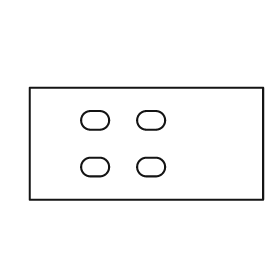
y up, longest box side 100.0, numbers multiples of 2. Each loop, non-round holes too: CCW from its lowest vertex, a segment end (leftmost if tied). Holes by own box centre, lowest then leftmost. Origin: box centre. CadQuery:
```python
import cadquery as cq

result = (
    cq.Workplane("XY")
    .moveTo(-50.0, -24.0)
    .lineTo(50.0, -24.0)
    .lineTo(50.0, 24.0)
    .lineTo(-50.0, 24.0)
    .close()
    .moveTo(-24.0, -14.0)
    .lineTo(-20.0, -14.0)
    .threePointArc((-16.0, -10.0), (-20.0, -6.0))
    .lineTo(-24.0, -6.0)
    .threePointArc((-28.0, -10.0), (-24.0, -14.0))
    .close()
    .moveTo(0.0, -14.0)
    .lineTo(4.0, -14.0)
    .threePointArc((8.0, -10.0), (4.0, -6.0))
    .lineTo(0.0, -6.0)
    .threePointArc((-4.0, -10.0), (0.0, -14.0))
    .close()
    .moveTo(-24.0, 6.0)
    .lineTo(-20.0, 6.0)
    .threePointArc((-16.0, 10.0), (-20.0, 14.0))
    .lineTo(-24.0, 14.0)
    .threePointArc((-28.0, 10.0), (-24.0, 6.0))
    .close()
    .moveTo(0.0, 6.0)
    .lineTo(4.0, 6.0)
    .threePointArc((8.0, 10.0), (4.0, 14.0))
    .lineTo(0.0, 14.0)
    .threePointArc((-4.0, 10.0), (0.0, 6.0))
    .close()
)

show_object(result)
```